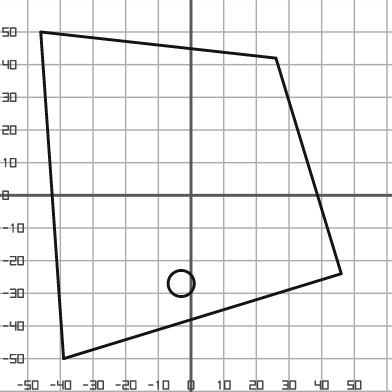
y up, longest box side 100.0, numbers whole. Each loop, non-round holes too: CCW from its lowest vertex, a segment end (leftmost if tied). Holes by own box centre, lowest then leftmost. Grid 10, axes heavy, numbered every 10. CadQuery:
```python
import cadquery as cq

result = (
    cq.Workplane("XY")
    .moveTo(-39.0, -50.0)
    .lineTo(46.0, -24.0)
    .lineTo(26.0, 42.0)
    .lineTo(-46.0, 50.0)
    .close()
    .moveTo(-3.0, -27.0)
    .circle(4.0)
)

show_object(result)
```